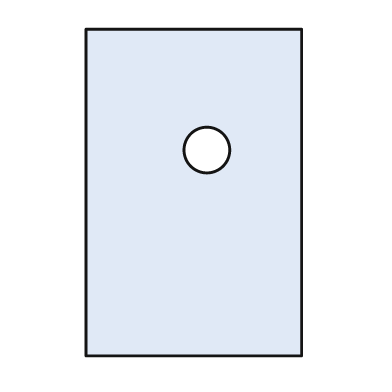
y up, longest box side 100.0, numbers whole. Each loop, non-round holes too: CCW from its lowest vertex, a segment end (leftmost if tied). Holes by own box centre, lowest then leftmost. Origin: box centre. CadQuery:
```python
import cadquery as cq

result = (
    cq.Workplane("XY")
    .moveTo(-33.0, -50.0)
    .lineTo(33.0, -50.0)
    .lineTo(33.0, 50.0)
    .lineTo(-33.0, 50.0)
    .close()
    .moveTo(4.0, 13.0)
    .circle(7.0)
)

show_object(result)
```